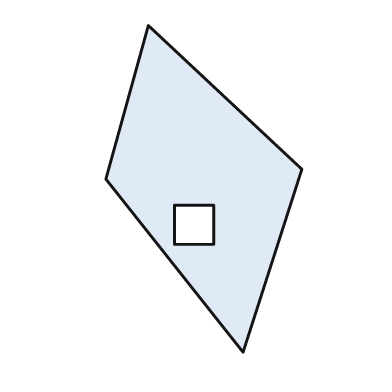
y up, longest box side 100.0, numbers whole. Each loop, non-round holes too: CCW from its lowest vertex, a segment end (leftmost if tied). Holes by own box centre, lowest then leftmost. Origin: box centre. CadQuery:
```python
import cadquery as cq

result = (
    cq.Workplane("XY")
    .moveTo(12.0, -50.0)
    .lineTo(30.0, 6.0)
    .lineTo(-17.0, 50.0)
    .lineTo(-30.0, 3.0)
    .close()
    .moveTo(-9.0, -17.0)
    .lineTo(3.0, -17.0)
    .lineTo(3.0, -5.0)
    .lineTo(-9.0, -5.0)
    .close()
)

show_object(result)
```